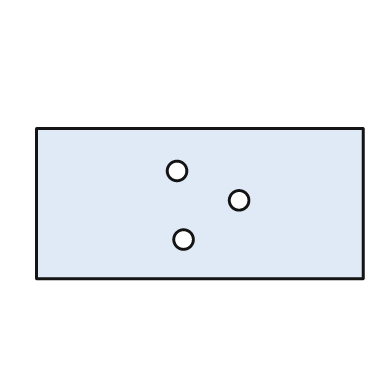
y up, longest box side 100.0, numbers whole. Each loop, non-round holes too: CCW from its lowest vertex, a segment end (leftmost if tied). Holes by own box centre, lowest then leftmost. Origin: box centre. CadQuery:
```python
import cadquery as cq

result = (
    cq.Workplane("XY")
    .moveTo(-50.0, -23.0)
    .lineTo(50.0, -23.0)
    .lineTo(50.0, 23.0)
    .lineTo(-50.0, 23.0)
    .close()
    .moveTo(-5.0, -11.0)
    .circle(3.0)
    .moveTo(12.0, 1.0)
    .circle(3.0)
    .moveTo(-7.0, 10.0)
    .circle(3.0)
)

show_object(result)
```